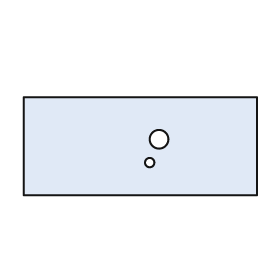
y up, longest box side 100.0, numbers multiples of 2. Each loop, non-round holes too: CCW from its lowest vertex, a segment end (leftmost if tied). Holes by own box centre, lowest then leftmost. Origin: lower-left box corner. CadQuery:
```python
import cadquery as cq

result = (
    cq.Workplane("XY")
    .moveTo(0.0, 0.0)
    .lineTo(100.0, 0.0)
    .lineTo(100.0, 42.0)
    .lineTo(0.0, 42.0)
    .close()
    .moveTo(54.0, 14.0)
    .circle(2.0)
    .moveTo(58.0, 24.0)
    .circle(4.0)
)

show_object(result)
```